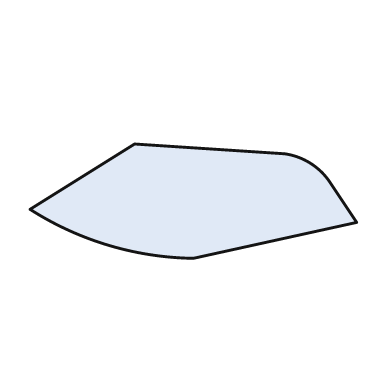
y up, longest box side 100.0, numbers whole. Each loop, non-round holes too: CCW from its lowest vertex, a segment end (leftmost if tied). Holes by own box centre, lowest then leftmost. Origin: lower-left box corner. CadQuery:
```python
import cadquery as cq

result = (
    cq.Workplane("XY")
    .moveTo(50.0, 0.0)
    .lineTo(100.0, 11.0)
    .lineTo(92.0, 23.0)
    .threePointArc((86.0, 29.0), (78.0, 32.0))
    .lineTo(32.0, 35.0)
    .lineTo(0.0, 15.0)
    .threePointArc((24.0, 4.0), (50.0, 0.0))
    .close()
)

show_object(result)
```